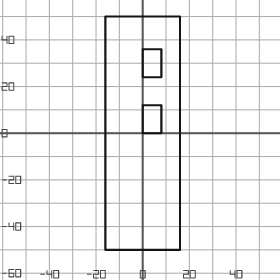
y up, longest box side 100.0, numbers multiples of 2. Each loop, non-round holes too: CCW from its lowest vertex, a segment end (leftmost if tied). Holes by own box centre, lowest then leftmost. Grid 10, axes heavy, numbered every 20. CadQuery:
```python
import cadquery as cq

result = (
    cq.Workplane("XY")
    .moveTo(-16.0, -50.0)
    .lineTo(16.0, -50.0)
    .lineTo(16.0, 50.0)
    .lineTo(-16.0, 50.0)
    .close()
    .moveTo(0.0, 0.0)
    .lineTo(8.0, 0.0)
    .lineTo(8.0, 12.0)
    .lineTo(0.0, 12.0)
    .close()
    .moveTo(0.0, 24.0)
    .lineTo(8.0, 24.0)
    .lineTo(8.0, 36.0)
    .lineTo(0.0, 36.0)
    .close()
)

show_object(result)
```